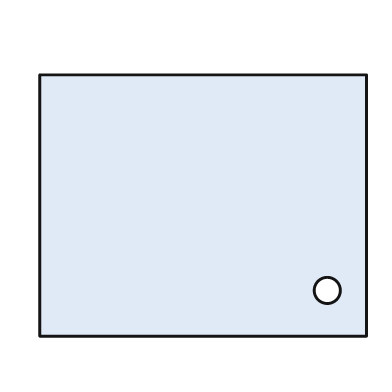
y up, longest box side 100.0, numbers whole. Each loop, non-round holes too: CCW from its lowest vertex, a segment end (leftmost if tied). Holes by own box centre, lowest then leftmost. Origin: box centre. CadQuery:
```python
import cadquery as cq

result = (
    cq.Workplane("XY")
    .moveTo(-50.0, -40.0)
    .lineTo(50.0, -40.0)
    .lineTo(50.0, 40.0)
    .lineTo(-50.0, 40.0)
    .close()
    .moveTo(38.0, -26.0)
    .circle(4.0)
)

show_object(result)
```